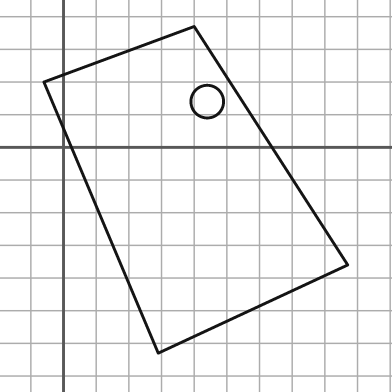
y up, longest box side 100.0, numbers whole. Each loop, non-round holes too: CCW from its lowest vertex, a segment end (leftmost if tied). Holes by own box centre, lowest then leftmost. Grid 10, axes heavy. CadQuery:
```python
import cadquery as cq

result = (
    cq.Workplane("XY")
    .moveTo(29.0, -63.0)
    .lineTo(87.0, -36.0)
    .lineTo(40.0, 37.0)
    .lineTo(-6.0, 20.0)
    .close()
    .moveTo(44.0, 14.0)
    .circle(5.0)
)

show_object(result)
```